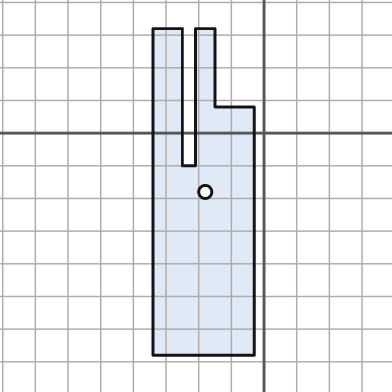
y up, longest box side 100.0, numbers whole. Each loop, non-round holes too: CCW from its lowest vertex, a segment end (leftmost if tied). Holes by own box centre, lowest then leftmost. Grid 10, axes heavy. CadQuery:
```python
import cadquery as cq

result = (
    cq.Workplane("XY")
    .moveTo(-34.0, -68.0)
    .lineTo(-3.0, -68.0)
    .lineTo(-3.0, 8.0)
    .lineTo(-15.0, 8.0)
    .lineTo(-15.0, 32.0)
    .lineTo(-21.0, 32.0)
    .lineTo(-21.0, -10.0)
    .lineTo(-25.0, -10.0)
    .lineTo(-25.0, 32.0)
    .lineTo(-34.0, 32.0)
    .close()
    .moveTo(-18.0, -18.0)
    .circle(2.0)
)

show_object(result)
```